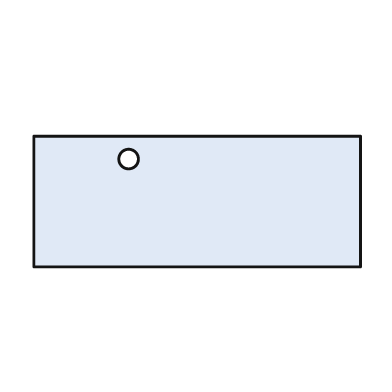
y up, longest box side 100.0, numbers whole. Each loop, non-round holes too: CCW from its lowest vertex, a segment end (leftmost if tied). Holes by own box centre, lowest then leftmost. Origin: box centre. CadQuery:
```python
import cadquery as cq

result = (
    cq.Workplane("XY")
    .moveTo(-50.0, -20.0)
    .lineTo(50.0, -20.0)
    .lineTo(50.0, 20.0)
    .lineTo(-50.0, 20.0)
    .close()
    .moveTo(-21.0, 13.0)
    .circle(3.0)
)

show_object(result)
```